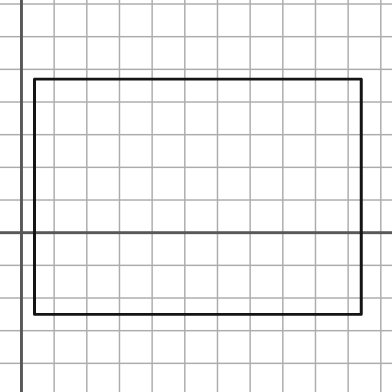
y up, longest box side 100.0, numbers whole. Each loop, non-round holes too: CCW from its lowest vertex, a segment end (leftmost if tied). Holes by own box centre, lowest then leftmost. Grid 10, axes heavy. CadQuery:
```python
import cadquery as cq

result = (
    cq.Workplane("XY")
    .moveTo(4.0, -25.0)
    .lineTo(104.0, -25.0)
    .lineTo(104.0, 47.0)
    .lineTo(4.0, 47.0)
    .close()
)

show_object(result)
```